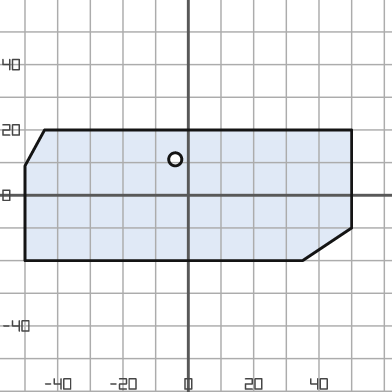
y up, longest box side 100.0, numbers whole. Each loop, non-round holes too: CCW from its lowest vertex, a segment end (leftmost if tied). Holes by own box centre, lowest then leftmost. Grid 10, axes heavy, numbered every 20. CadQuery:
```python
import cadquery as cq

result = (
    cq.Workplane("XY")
    .moveTo(-50.0, -20.0)
    .lineTo(35.0, -20.0)
    .lineTo(50.0, -10.0)
    .lineTo(50.0, 20.0)
    .lineTo(-44.0, 20.0)
    .lineTo(-50.0, 9.0)
    .close()
    .moveTo(-4.0, 11.0)
    .circle(2.0)
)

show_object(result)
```